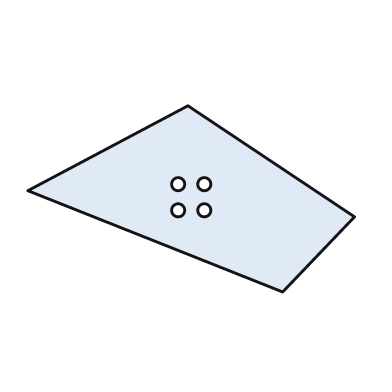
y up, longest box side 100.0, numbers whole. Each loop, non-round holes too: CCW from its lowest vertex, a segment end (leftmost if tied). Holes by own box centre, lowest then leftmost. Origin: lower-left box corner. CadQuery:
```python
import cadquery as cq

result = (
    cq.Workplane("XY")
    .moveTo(78.0, 0.0)
    .lineTo(100.0, 23.0)
    .lineTo(49.0, 57.0)
    .lineTo(0.0, 31.0)
    .close()
    .moveTo(46.0, 25.0)
    .circle(2.0)
    .moveTo(54.0, 25.0)
    .circle(2.0)
    .moveTo(46.0, 33.0)
    .circle(2.0)
    .moveTo(54.0, 33.0)
    .circle(2.0)
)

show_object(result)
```